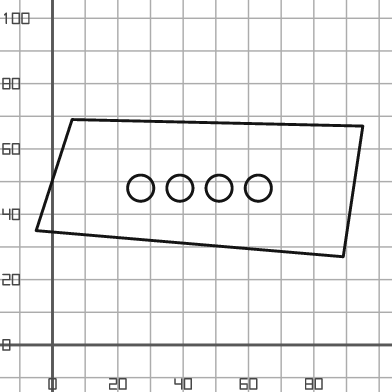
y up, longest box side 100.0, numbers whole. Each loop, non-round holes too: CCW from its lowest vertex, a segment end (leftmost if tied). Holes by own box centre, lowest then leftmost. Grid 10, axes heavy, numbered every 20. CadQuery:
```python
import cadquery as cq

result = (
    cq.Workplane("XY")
    .moveTo(89.0, 27.0)
    .lineTo(95.0, 67.0)
    .lineTo(6.0, 69.0)
    .lineTo(-5.0, 35.0)
    .close()
    .moveTo(27.0, 48.0)
    .circle(4.0)
    .moveTo(39.0, 48.0)
    .circle(4.0)
    .moveTo(51.0, 48.0)
    .circle(4.0)
    .moveTo(63.0, 48.0)
    .circle(4.0)
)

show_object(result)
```